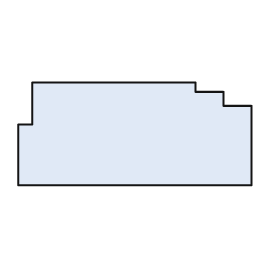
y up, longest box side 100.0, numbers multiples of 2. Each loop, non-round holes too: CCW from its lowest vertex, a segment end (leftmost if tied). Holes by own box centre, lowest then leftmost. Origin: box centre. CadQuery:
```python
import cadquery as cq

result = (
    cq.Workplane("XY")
    .moveTo(-50.0, -22.0)
    .lineTo(50.0, -22.0)
    .lineTo(50.0, 12.0)
    .lineTo(38.0, 12.0)
    .lineTo(38.0, 18.0)
    .lineTo(26.0, 18.0)
    .lineTo(26.0, 22.0)
    .lineTo(-44.0, 22.0)
    .lineTo(-44.0, 4.0)
    .lineTo(-50.0, 4.0)
    .close()
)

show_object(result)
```